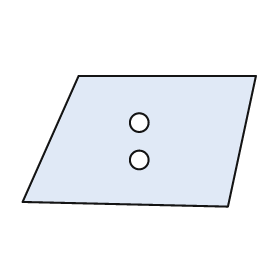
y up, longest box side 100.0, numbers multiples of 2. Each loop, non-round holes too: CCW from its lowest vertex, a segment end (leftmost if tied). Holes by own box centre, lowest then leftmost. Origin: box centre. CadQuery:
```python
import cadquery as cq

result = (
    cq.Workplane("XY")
    .moveTo(38.0, -28.0)
    .lineTo(50.0, 28.0)
    .lineTo(-26.0, 28.0)
    .lineTo(-50.0, -26.0)
    .close()
    .moveTo(0.0, -8.0)
    .circle(4.0)
    .moveTo(0.0, 8.0)
    .circle(4.0)
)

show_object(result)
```